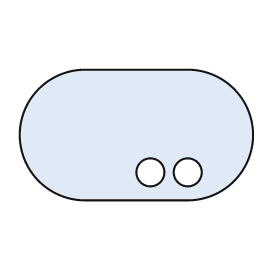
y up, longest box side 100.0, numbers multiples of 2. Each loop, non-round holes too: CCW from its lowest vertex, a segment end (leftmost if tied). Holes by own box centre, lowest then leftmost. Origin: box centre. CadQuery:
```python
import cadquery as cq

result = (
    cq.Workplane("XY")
    .moveTo(-22.0, -28.0)
    .lineTo(22.0, -28.0)
    .threePointArc((50.0, 0.0), (22.0, 28.0))
    .lineTo(-22.0, 28.0)
    .threePointArc((-50.0, 0.0), (-22.0, -28.0))
    .close()
    .moveTo(6.0, -16.0)
    .circle(6.0)
    .moveTo(22.0, -16.0)
    .circle(6.0)
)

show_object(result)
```